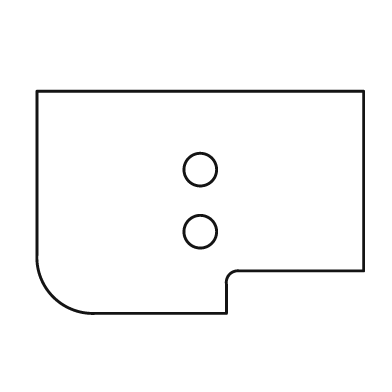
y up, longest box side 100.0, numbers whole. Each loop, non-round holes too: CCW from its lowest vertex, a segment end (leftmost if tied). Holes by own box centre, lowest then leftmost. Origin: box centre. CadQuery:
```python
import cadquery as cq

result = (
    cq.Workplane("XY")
    .moveTo(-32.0, -34.0)
    .lineTo(8.0, -34.0)
    .lineTo(8.0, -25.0)
    .threePointArc((9.0, -22.0), (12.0, -21.0))
    .lineTo(50.0, -21.0)
    .lineTo(50.0, 34.0)
    .lineTo(-50.0, 34.0)
    .lineTo(-50.0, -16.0)
    .threePointArc((-45.0, -29.0), (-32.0, -34.0))
    .close()
    .moveTo(0.0, -9.0)
    .circle(5.0)
    .moveTo(0.0, 10.0)
    .circle(5.0)
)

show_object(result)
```